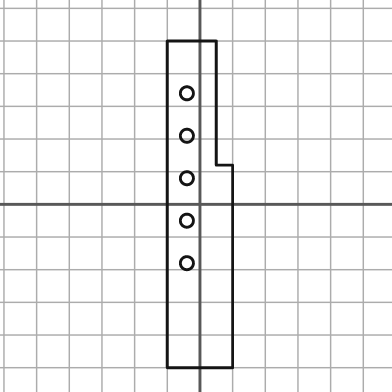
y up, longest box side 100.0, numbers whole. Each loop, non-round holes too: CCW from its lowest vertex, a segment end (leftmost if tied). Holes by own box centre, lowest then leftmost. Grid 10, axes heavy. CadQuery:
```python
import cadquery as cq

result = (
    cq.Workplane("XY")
    .moveTo(-10.0, -50.0)
    .lineTo(10.0, -50.0)
    .lineTo(10.0, 12.0)
    .lineTo(5.0, 12.0)
    .lineTo(5.0, 50.0)
    .lineTo(-10.0, 50.0)
    .close()
    .moveTo(-4.0, -18.0)
    .circle(2.0)
    .moveTo(-4.0, -5.0)
    .circle(2.0)
    .moveTo(-4.0, 8.0)
    .circle(2.0)
    .moveTo(-4.0, 21.0)
    .circle(2.0)
    .moveTo(-4.0, 34.0)
    .circle(2.0)
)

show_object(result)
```